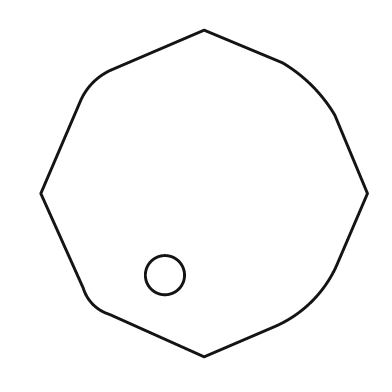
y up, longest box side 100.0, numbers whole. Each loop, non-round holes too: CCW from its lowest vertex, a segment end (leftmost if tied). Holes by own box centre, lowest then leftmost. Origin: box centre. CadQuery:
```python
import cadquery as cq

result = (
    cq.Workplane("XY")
    .moveTo(0.0, -50.0)
    .lineTo(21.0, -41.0)
    .threePointArc((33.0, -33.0), (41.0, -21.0))
    .lineTo(50.0, 0.0)
    .lineTo(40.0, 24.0)
    .threePointArc((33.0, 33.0), (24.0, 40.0))
    .lineTo(0.0, 50.0)
    .lineTo(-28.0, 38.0)
    .threePointArc((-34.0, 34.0), (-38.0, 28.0))
    .lineTo(-50.0, 0.0)
    .lineTo(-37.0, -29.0)
    .threePointArc((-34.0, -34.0), (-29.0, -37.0))
    .close()
    .moveTo(-12.0, -25.0)
    .circle(6.0)
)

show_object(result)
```